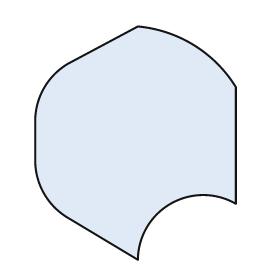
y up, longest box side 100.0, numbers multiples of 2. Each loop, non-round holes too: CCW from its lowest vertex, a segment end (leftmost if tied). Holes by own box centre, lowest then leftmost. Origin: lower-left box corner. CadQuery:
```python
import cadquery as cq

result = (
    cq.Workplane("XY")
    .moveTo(44.0, 0.0)
    .threePointArc((58.0, 24.0), (86.0, 24.0))
    .lineTo(86.0, 74.0)
    .threePointArc((68.0, 92.0), (44.0, 100.0))
    .lineTo(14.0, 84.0)
    .threePointArc((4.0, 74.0), (0.0, 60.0))
    .lineTo(0.0, 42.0)
    .threePointArc((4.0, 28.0), (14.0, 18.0))
    .close()
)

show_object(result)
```